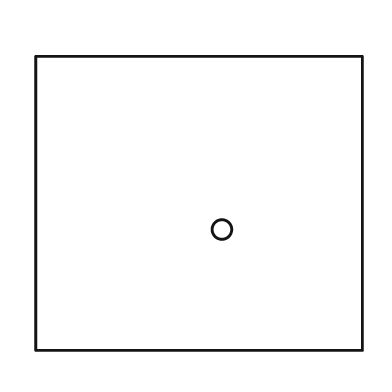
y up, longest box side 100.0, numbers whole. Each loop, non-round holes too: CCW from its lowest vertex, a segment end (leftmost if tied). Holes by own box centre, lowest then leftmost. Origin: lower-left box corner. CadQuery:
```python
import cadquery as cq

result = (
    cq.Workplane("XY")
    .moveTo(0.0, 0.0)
    .lineTo(100.0, 0.0)
    .lineTo(100.0, 90.0)
    .lineTo(0.0, 90.0)
    .close()
    .moveTo(57.0, 37.0)
    .circle(3.0)
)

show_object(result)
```